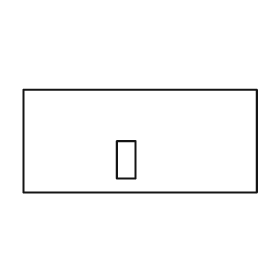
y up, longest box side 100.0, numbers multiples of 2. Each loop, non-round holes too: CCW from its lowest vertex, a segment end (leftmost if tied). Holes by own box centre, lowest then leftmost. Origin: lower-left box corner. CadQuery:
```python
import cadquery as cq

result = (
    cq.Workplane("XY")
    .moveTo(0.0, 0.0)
    .lineTo(100.0, 0.0)
    .lineTo(100.0, 44.0)
    .lineTo(0.0, 44.0)
    .close()
    .moveTo(40.0, 6.0)
    .lineTo(48.0, 6.0)
    .lineTo(48.0, 22.0)
    .lineTo(40.0, 22.0)
    .close()
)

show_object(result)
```